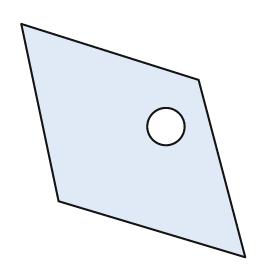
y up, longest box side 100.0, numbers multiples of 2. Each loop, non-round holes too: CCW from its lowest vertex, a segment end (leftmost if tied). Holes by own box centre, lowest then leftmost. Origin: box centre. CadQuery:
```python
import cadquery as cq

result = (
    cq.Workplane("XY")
    .moveTo(48.0, -50.0)
    .lineTo(28.0, 26.0)
    .lineTo(-48.0, 50.0)
    .lineTo(-32.0, -26.0)
    .close()
    .moveTo(14.0, 6.0)
    .circle(8.0)
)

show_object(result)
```